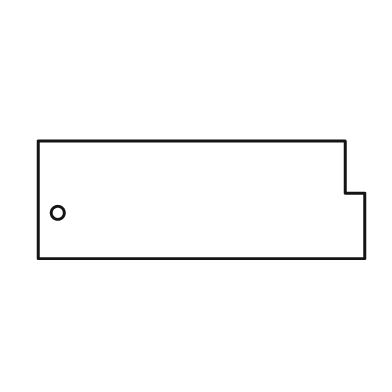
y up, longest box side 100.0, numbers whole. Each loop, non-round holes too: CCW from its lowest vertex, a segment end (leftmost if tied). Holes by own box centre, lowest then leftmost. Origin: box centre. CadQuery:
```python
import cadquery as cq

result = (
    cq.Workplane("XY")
    .moveTo(-50.0, -18.0)
    .lineTo(50.0, -18.0)
    .lineTo(50.0, 2.0)
    .lineTo(44.0, 2.0)
    .lineTo(44.0, 18.0)
    .lineTo(-50.0, 18.0)
    .close()
    .moveTo(-44.0, -4.0)
    .circle(2.0)
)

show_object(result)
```